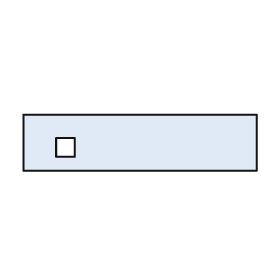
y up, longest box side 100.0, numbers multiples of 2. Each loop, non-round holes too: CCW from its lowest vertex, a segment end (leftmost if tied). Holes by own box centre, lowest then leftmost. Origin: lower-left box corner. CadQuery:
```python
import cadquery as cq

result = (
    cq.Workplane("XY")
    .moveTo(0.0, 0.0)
    .lineTo(100.0, 0.0)
    .lineTo(100.0, 24.0)
    .lineTo(0.0, 24.0)
    .close()
    .moveTo(14.0, 6.0)
    .lineTo(22.0, 6.0)
    .lineTo(22.0, 14.0)
    .lineTo(14.0, 14.0)
    .close()
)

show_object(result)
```